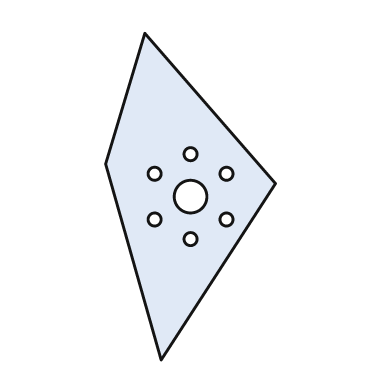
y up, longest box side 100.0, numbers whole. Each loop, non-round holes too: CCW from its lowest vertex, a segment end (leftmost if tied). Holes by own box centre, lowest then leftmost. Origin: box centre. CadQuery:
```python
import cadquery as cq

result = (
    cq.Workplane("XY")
    .moveTo(-9.0, -50.0)
    .lineTo(26.0, 4.0)
    .lineTo(-14.0, 50.0)
    .lineTo(-26.0, 10.0)
    .close()
    .moveTo(0.0, -13.0)
    .circle(2.0)
    .moveTo(-11.0, -7.0)
    .circle(2.0)
    .moveTo(11.0, -7.0)
    .circle(2.0)
    .moveTo(0.0, 0.0)
    .circle(5.0)
    .moveTo(-11.0, 7.0)
    .circle(2.0)
    .moveTo(11.0, 7.0)
    .circle(2.0)
    .moveTo(0.0, 13.0)
    .circle(2.0)
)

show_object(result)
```